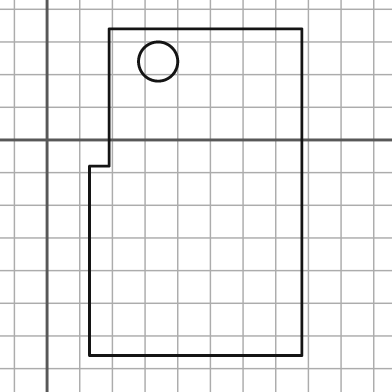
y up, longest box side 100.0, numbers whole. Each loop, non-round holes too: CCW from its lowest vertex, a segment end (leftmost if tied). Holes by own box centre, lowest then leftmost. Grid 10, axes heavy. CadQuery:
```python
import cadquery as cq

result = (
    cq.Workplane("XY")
    .moveTo(13.0, -66.0)
    .lineTo(78.0, -66.0)
    .lineTo(78.0, 34.0)
    .lineTo(19.0, 34.0)
    .lineTo(19.0, -8.0)
    .lineTo(13.0, -8.0)
    .close()
    .moveTo(34.0, 24.0)
    .circle(6.0)
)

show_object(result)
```